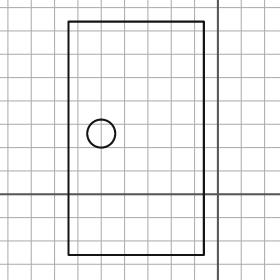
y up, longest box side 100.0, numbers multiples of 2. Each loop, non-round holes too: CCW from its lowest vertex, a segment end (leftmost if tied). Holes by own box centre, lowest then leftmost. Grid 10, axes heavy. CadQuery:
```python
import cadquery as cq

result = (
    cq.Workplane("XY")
    .moveTo(-64.0, -26.0)
    .lineTo(-6.0, -26.0)
    .lineTo(-6.0, 74.0)
    .lineTo(-64.0, 74.0)
    .close()
    .moveTo(-50.0, 26.0)
    .circle(6.0)
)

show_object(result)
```